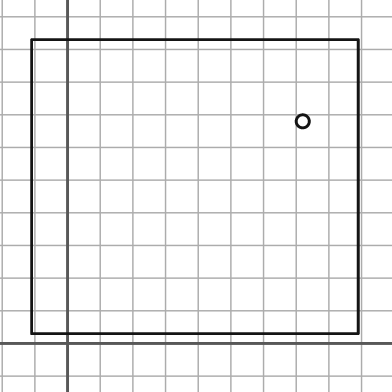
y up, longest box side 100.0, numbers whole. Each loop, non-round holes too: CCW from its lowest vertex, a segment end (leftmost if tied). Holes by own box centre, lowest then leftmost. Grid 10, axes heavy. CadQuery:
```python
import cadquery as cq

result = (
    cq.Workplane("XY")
    .moveTo(-11.0, 3.0)
    .lineTo(89.0, 3.0)
    .lineTo(89.0, 93.0)
    .lineTo(-11.0, 93.0)
    .close()
    .moveTo(72.0, 68.0)
    .circle(2.0)
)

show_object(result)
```